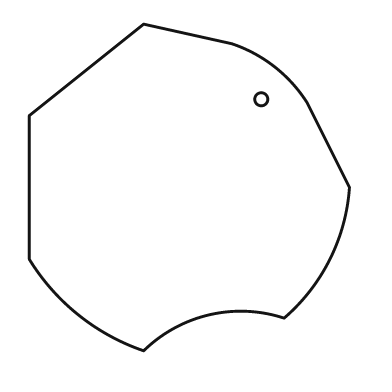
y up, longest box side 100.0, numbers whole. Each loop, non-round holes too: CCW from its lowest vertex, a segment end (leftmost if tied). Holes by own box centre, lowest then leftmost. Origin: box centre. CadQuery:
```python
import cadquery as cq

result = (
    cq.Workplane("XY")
    .moveTo(-14.0, -50.0)
    .threePointArc((6.0, -39.0), (29.0, -40.0))
    .threePointArc((43.0, -22.0), (49.0, 0.0))
    .lineTo(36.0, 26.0)
    .threePointArc((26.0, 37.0), (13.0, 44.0))
    .lineTo(-14.0, 50.0)
    .lineTo(-49.0, 22.0)
    .lineTo(-49.0, -22.0)
    .threePointArc((-34.0, -39.0), (-14.0, -50.0))
    .close()
    .moveTo(22.0, 27.0)
    .circle(2.0)
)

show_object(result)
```